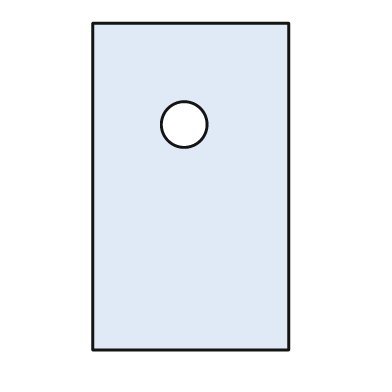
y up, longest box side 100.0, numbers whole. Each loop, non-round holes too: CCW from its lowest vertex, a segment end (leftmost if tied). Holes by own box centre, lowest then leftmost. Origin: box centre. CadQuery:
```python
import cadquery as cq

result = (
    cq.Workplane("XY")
    .moveTo(-30.0, -50.0)
    .lineTo(30.0, -50.0)
    .lineTo(30.0, 50.0)
    .lineTo(-30.0, 50.0)
    .close()
    .moveTo(-2.0, 19.0)
    .circle(7.0)
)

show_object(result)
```